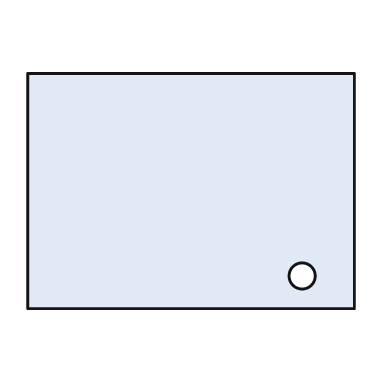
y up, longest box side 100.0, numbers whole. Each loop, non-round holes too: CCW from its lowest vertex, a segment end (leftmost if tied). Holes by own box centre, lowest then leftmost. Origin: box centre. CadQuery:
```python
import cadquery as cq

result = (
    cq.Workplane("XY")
    .moveTo(-50.0, -36.0)
    .lineTo(50.0, -36.0)
    .lineTo(50.0, 36.0)
    .lineTo(-50.0, 36.0)
    .close()
    .moveTo(34.0, -26.0)
    .circle(4.0)
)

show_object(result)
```